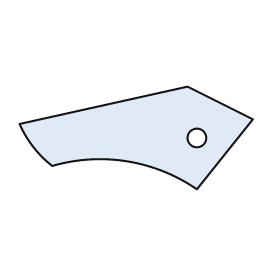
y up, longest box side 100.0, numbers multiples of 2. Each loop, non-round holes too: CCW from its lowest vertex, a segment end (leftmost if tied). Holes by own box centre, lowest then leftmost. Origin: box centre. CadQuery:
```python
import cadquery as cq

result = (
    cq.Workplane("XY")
    .moveTo(26.0, -22.0)
    .lineTo(50.0, 8.0)
    .lineTo(22.0, 22.0)
    .lineTo(-50.0, 6.0)
    .threePointArc((-44.0, -4.0), (-36.0, -12.0))
    .threePointArc((-4.0, -10.0), (26.0, -22.0))
    .close()
    .moveTo(26.0, 0.0)
    .circle(4.0)
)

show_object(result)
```